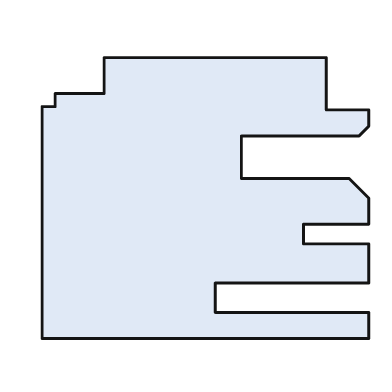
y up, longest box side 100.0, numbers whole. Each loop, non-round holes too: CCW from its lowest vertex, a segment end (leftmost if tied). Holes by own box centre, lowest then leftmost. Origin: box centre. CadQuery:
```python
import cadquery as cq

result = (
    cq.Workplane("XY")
    .moveTo(-50.0, -43.0)
    .lineTo(50.0, -43.0)
    .lineTo(50.0, -35.0)
    .lineTo(3.0, -35.0)
    .lineTo(3.0, -26.0)
    .lineTo(50.0, -26.0)
    .lineTo(50.0, -14.0)
    .lineTo(30.0, -14.0)
    .lineTo(30.0, -8.0)
    .lineTo(50.0, -8.0)
    .lineTo(50.0, 0.0)
    .lineTo(44.0, 6.0)
    .lineTo(11.0, 6.0)
    .lineTo(11.0, 19.0)
    .lineTo(47.0, 19.0)
    .lineTo(50.0, 22.0)
    .lineTo(50.0, 27.0)
    .lineTo(37.0, 27.0)
    .lineTo(37.0, 43.0)
    .lineTo(-31.0, 43.0)
    .lineTo(-31.0, 32.0)
    .lineTo(-46.0, 32.0)
    .lineTo(-46.0, 28.0)
    .lineTo(-50.0, 28.0)
    .close()
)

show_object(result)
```